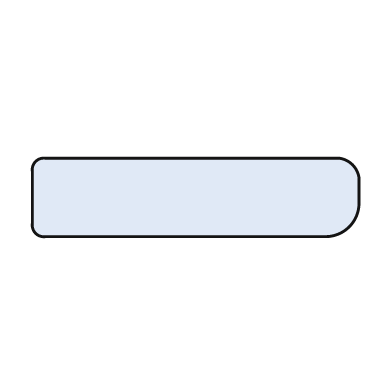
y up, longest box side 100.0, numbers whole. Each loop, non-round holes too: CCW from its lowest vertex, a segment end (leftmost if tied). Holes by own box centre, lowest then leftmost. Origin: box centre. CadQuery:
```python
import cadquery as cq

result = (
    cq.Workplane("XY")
    .moveTo(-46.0, -12.0)
    .lineTo(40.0, -12.0)
    .threePointArc((47.0, -9.0), (50.0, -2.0))
    .lineTo(50.0, 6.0)
    .threePointArc((48.0, 10.0), (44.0, 12.0))
    .lineTo(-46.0, 12.0)
    .threePointArc((-49.0, 11.0), (-50.0, 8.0))
    .lineTo(-50.0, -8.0)
    .threePointArc((-49.0, -11.0), (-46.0, -12.0))
    .close()
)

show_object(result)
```